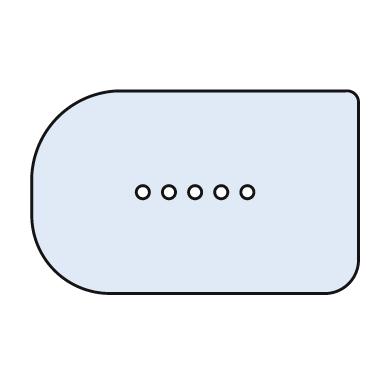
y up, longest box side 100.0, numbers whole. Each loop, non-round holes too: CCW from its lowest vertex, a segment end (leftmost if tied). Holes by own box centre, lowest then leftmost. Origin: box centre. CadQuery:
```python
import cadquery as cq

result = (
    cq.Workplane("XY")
    .moveTo(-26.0, -31.0)
    .lineTo(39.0, -31.0)
    .threePointArc((47.0, -28.0), (50.0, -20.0))
    .lineTo(50.0, 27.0)
    .threePointArc((49.0, 30.0), (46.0, 31.0))
    .lineTo(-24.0, 31.0)
    .threePointArc((-42.0, 23.0), (-50.0, 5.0))
    .lineTo(-50.0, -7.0)
    .threePointArc((-43.0, -24.0), (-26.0, -31.0))
    .close()
    .moveTo(-16.0, 0.0)
    .circle(2.0)
    .moveTo(-8.0, 0.0)
    .circle(2.0)
    .moveTo(0.0, 0.0)
    .circle(2.0)
    .moveTo(8.0, 0.0)
    .circle(2.0)
    .moveTo(16.0, 0.0)
    .circle(2.0)
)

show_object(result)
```